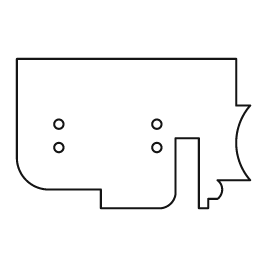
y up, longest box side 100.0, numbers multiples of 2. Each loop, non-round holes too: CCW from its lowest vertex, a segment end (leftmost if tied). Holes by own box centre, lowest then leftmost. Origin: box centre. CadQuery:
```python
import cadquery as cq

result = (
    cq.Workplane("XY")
    .moveTo(-14.0, -32.0)
    .lineTo(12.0, -32.0)
    .threePointArc((16.0, -30.0), (18.0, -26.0))
    .lineTo(18.0, -2.0)
    .lineTo(28.0, -2.0)
    .lineTo(28.0, -32.0)
    .lineTo(32.0, -32.0)
    .lineTo(32.0, -28.0)
    .lineTo(36.0, -28.0)
    .threePointArc((38.0, -24.0), (36.0, -20.0))
    .lineTo(50.0, -20.0)
    .threePointArc((44.0, -4.0), (50.0, 12.0))
    .lineTo(44.0, 12.0)
    .lineTo(44.0, 32.0)
    .lineTo(-50.0, 32.0)
    .lineTo(-50.0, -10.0)
    .threePointArc((-46.0, -20.0), (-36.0, -24.0))
    .lineTo(-14.0, -24.0)
    .close()
    .moveTo(-32.0, -6.0)
    .circle(2.0)
    .moveTo(10.0, -6.0)
    .circle(2.0)
    .moveTo(-32.0, 4.0)
    .circle(2.0)
    .moveTo(10.0, 4.0)
    .circle(2.0)
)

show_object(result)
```